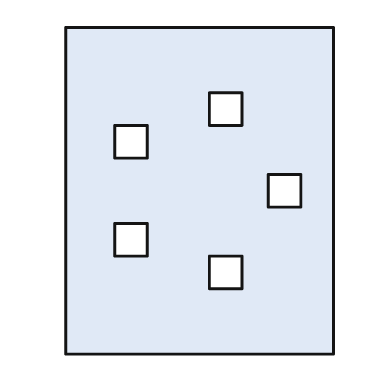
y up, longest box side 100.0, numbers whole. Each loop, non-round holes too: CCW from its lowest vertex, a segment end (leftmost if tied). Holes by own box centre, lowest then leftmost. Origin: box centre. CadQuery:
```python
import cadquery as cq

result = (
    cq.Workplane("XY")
    .moveTo(-41.0, -50.0)
    .lineTo(41.0, -50.0)
    .lineTo(41.0, 50.0)
    .lineTo(-41.0, 50.0)
    .close()
    .moveTo(3.0, -30.0)
    .lineTo(13.0, -30.0)
    .lineTo(13.0, -20.0)
    .lineTo(3.0, -20.0)
    .close()
    .moveTo(-26.0, -20.0)
    .lineTo(-16.0, -20.0)
    .lineTo(-16.0, -10.0)
    .lineTo(-26.0, -10.0)
    .close()
    .moveTo(21.0, -5.0)
    .lineTo(31.0, -5.0)
    .lineTo(31.0, 5.0)
    .lineTo(21.0, 5.0)
    .close()
    .moveTo(-26.0, 10.0)
    .lineTo(-16.0, 10.0)
    .lineTo(-16.0, 20.0)
    .lineTo(-26.0, 20.0)
    .close()
    .moveTo(3.0, 20.0)
    .lineTo(13.0, 20.0)
    .lineTo(13.0, 30.0)
    .lineTo(3.0, 30.0)
    .close()
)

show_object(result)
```